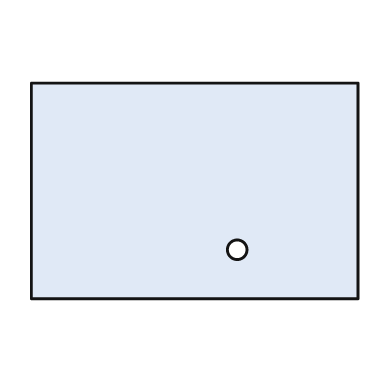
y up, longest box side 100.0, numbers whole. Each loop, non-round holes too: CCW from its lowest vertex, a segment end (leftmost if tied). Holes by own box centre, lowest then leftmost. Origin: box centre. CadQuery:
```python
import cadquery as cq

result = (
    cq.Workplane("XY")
    .moveTo(-50.0, -33.0)
    .lineTo(50.0, -33.0)
    .lineTo(50.0, 33.0)
    .lineTo(-50.0, 33.0)
    .close()
    .moveTo(13.0, -18.0)
    .circle(3.0)
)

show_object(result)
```